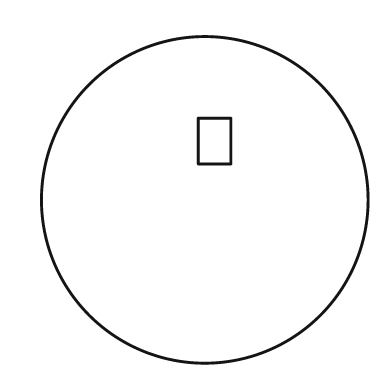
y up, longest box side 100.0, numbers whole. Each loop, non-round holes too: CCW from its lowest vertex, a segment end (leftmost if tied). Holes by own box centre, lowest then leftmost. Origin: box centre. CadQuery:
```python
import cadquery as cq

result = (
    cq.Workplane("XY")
    .moveTo(0.0, 0.0)
    .circle(50.0)
    .moveTo(-2.0, 11.0)
    .lineTo(8.0, 11.0)
    .lineTo(8.0, 25.0)
    .lineTo(-2.0, 25.0)
    .close()
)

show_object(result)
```